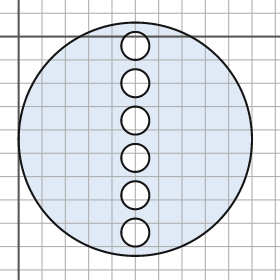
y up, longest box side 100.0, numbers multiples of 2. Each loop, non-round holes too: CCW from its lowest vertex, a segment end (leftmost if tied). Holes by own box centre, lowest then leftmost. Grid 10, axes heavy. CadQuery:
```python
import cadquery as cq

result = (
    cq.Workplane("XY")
    .moveTo(50.0, -44.0)
    .circle(50.0)
    .moveTo(50.0, -84.0)
    .circle(6.0)
    .moveTo(50.0, -68.0)
    .circle(6.0)
    .moveTo(50.0, -52.0)
    .circle(6.0)
    .moveTo(50.0, -36.0)
    .circle(6.0)
    .moveTo(50.0, -20.0)
    .circle(6.0)
    .moveTo(50.0, -4.0)
    .circle(6.0)
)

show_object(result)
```